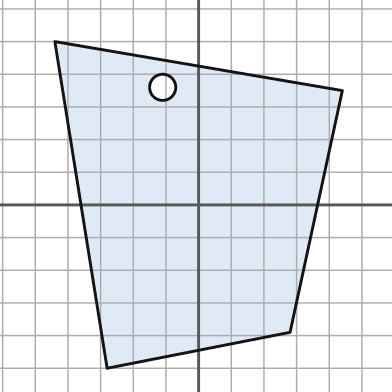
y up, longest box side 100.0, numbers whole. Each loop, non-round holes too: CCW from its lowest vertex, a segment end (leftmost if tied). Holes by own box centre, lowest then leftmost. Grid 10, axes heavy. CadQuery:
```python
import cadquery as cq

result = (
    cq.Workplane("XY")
    .moveTo(-28.0, -50.0)
    .lineTo(28.0, -39.0)
    .lineTo(44.0, 35.0)
    .lineTo(-44.0, 50.0)
    .close()
    .moveTo(-11.0, 36.0)
    .circle(4.0)
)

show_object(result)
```